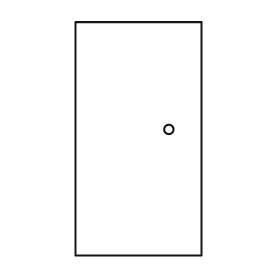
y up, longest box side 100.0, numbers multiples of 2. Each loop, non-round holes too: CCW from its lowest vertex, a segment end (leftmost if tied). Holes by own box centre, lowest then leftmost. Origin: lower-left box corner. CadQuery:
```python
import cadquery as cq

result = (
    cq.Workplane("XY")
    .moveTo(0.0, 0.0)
    .lineTo(54.0, 0.0)
    .lineTo(54.0, 100.0)
    .lineTo(0.0, 100.0)
    .close()
    .moveTo(40.0, 54.0)
    .circle(2.0)
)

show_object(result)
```